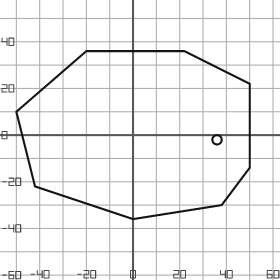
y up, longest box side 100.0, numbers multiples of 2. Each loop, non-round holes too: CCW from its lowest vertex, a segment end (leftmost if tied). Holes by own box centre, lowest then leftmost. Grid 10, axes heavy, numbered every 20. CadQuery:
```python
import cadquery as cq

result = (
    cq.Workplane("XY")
    .moveTo(0.0, -36.0)
    .lineTo(38.0, -30.0)
    .lineTo(50.0, -14.0)
    .lineTo(50.0, 22.0)
    .lineTo(22.0, 36.0)
    .lineTo(-20.0, 36.0)
    .lineTo(-50.0, 10.0)
    .lineTo(-42.0, -22.0)
    .close()
    .moveTo(36.0, -2.0)
    .circle(2.0)
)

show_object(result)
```